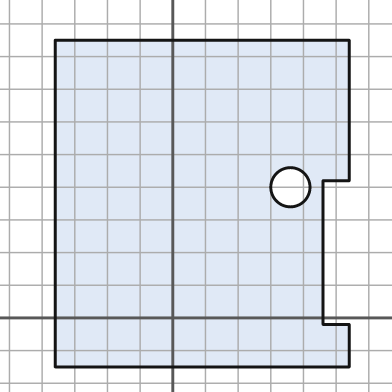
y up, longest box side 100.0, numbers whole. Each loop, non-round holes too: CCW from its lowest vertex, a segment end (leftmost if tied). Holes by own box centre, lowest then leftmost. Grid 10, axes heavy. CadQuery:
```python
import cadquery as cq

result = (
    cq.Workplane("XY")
    .moveTo(-36.0, -15.0)
    .lineTo(54.0, -15.0)
    .lineTo(54.0, -2.0)
    .lineTo(46.0, -2.0)
    .lineTo(46.0, 42.0)
    .lineTo(54.0, 42.0)
    .lineTo(54.0, 85.0)
    .lineTo(-36.0, 85.0)
    .close()
    .moveTo(36.0, 40.0)
    .circle(6.0)
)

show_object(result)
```